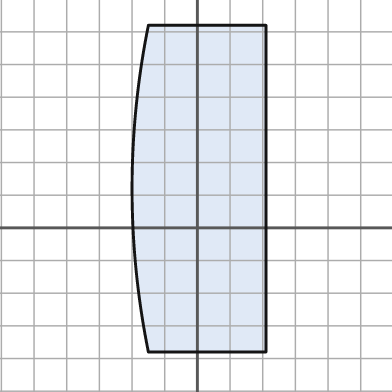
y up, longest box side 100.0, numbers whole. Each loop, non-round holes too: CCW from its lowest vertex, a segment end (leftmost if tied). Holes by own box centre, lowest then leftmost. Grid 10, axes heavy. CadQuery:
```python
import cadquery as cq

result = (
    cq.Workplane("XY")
    .moveTo(-15.0, -38.0)
    .lineTo(21.0, -38.0)
    .lineTo(21.0, 62.0)
    .lineTo(-15.0, 62.0)
    .threePointArc((-20.0, 12.0), (-15.0, -38.0))
    .close()
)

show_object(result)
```